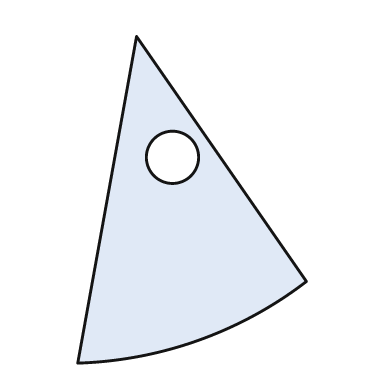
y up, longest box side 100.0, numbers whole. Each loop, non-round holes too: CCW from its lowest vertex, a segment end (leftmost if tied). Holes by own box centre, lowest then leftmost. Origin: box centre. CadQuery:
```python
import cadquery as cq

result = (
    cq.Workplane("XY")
    .moveTo(-35.0, -50.0)
    .threePointArc((2.0, -43.0), (35.0, -25.0))
    .lineTo(-17.0, 50.0)
    .close()
    .moveTo(-6.0, 13.0)
    .circle(8.0)
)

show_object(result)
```